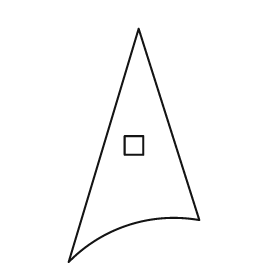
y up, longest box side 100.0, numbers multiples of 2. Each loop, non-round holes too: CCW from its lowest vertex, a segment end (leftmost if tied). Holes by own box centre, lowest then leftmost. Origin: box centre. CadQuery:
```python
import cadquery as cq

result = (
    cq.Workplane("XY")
    .moveTo(-28.0, -50.0)
    .threePointArc((-2.0, -34.0), (28.0, -32.0))
    .lineTo(2.0, 50.0)
    .close()
    .moveTo(-4.0, -4.0)
    .lineTo(4.0, -4.0)
    .lineTo(4.0, 4.0)
    .lineTo(-4.0, 4.0)
    .close()
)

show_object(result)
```